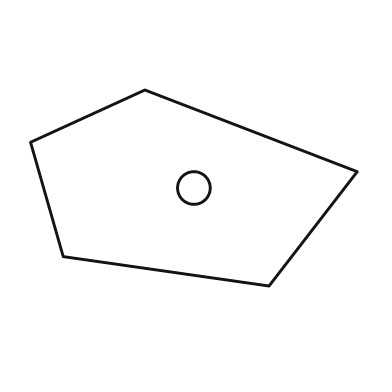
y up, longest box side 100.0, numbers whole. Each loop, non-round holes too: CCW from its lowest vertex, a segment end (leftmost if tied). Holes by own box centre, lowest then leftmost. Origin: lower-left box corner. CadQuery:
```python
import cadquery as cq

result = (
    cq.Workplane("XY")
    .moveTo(73.0, 0.0)
    .lineTo(100.0, 35.0)
    .lineTo(35.0, 60.0)
    .lineTo(0.0, 44.0)
    .lineTo(10.0, 9.0)
    .close()
    .moveTo(50.0, 30.0)
    .circle(5.0)
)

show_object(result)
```